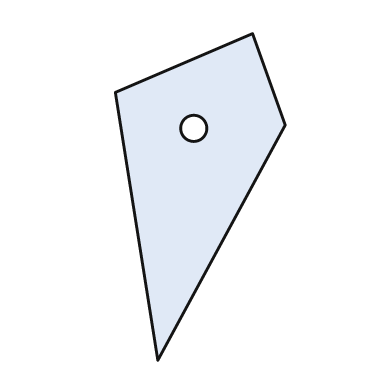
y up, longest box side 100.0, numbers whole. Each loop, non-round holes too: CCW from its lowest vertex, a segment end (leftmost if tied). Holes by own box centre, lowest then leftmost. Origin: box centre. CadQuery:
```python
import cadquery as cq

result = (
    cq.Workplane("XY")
    .moveTo(-13.0, -50.0)
    .lineTo(26.0, 22.0)
    .lineTo(16.0, 50.0)
    .lineTo(-26.0, 32.0)
    .close()
    .moveTo(-2.0, 21.0)
    .circle(4.0)
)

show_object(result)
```